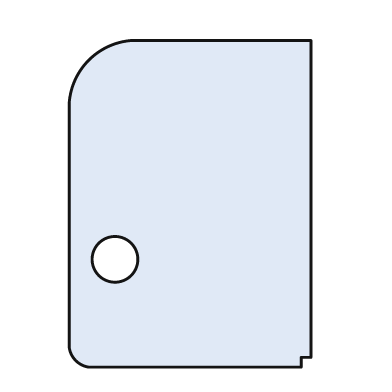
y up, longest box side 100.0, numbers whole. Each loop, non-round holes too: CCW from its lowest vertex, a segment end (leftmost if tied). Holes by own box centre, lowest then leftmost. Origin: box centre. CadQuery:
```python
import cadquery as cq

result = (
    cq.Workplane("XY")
    .moveTo(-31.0, -50.0)
    .lineTo(34.0, -50.0)
    .lineTo(34.0, -47.0)
    .lineTo(37.0, -47.0)
    .lineTo(37.0, 50.0)
    .lineTo(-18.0, 50.0)
    .threePointArc((-31.0, 44.0), (-37.0, 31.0))
    .lineTo(-37.0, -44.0)
    .threePointArc((-35.0, -48.0), (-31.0, -50.0))
    .close()
    .moveTo(-23.0, -17.0)
    .circle(7.0)
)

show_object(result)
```